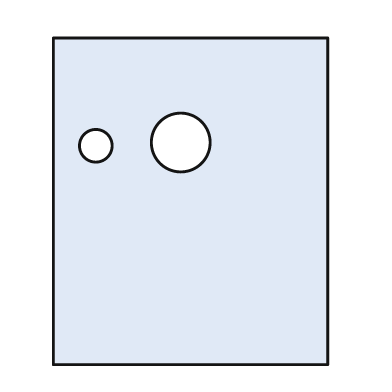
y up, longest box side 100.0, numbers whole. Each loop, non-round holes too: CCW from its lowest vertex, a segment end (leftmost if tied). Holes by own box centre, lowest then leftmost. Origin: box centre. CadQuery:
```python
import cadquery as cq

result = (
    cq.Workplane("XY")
    .moveTo(-42.0, -50.0)
    .lineTo(42.0, -50.0)
    .lineTo(42.0, 50.0)
    .lineTo(-42.0, 50.0)
    .close()
    .moveTo(-29.0, 17.0)
    .circle(5.0)
    .moveTo(-3.0, 18.0)
    .circle(9.0)
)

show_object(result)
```